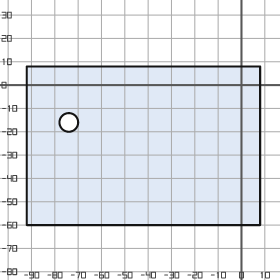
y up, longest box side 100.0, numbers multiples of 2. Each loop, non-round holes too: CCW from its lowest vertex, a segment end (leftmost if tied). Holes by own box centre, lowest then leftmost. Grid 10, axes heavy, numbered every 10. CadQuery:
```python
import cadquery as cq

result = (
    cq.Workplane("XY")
    .moveTo(-92.0, -60.0)
    .lineTo(8.0, -60.0)
    .lineTo(8.0, 8.0)
    .lineTo(-92.0, 8.0)
    .close()
    .moveTo(-74.0, -16.0)
    .circle(4.0)
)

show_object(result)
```